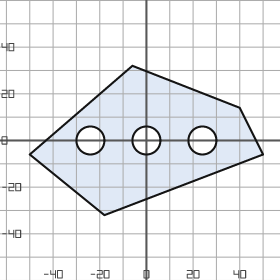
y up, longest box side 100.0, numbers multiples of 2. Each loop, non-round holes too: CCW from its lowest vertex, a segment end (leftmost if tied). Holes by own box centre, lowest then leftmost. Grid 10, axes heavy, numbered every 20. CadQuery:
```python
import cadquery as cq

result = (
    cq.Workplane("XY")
    .moveTo(-18.0, -32.0)
    .lineTo(50.0, -6.0)
    .lineTo(40.0, 14.0)
    .lineTo(-6.0, 32.0)
    .lineTo(-50.0, -6.0)
    .close()
    .moveTo(-24.0, 0.0)
    .circle(6.0)
    .moveTo(0.0, 0.0)
    .circle(6.0)
    .moveTo(24.0, 0.0)
    .circle(6.0)
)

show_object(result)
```